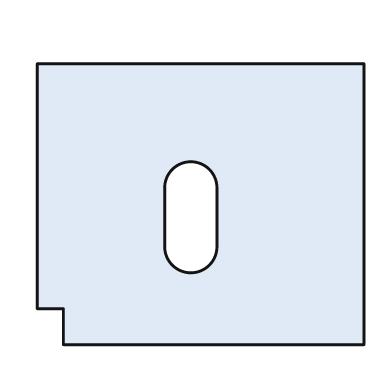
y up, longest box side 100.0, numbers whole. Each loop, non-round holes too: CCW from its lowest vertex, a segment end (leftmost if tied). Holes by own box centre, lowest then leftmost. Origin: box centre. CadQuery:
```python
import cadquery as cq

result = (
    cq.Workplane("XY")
    .moveTo(-42.0, -43.0)
    .lineTo(50.0, -43.0)
    .lineTo(50.0, 43.0)
    .lineTo(-50.0, 43.0)
    .lineTo(-50.0, -32.0)
    .lineTo(-42.0, -32.0)
    .close()
    .moveTo(-11.0, -13.0)
    .threePointArc((-3.0, -21.0), (5.0, -13.0))
    .lineTo(5.0, 5.0)
    .threePointArc((-3.0, 13.0), (-11.0, 5.0))
    .close()
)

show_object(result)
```